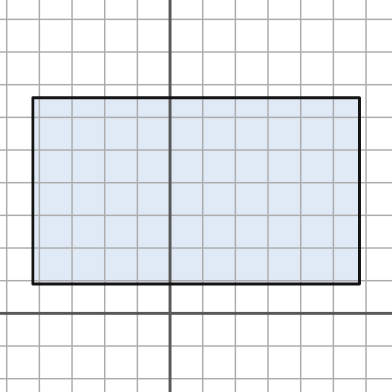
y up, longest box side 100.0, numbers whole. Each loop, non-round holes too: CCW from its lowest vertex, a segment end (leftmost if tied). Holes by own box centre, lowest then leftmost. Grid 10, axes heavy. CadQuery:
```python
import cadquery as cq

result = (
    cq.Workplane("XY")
    .moveTo(-42.0, 9.0)
    .lineTo(58.0, 9.0)
    .lineTo(58.0, 66.0)
    .lineTo(-42.0, 66.0)
    .close()
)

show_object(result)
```